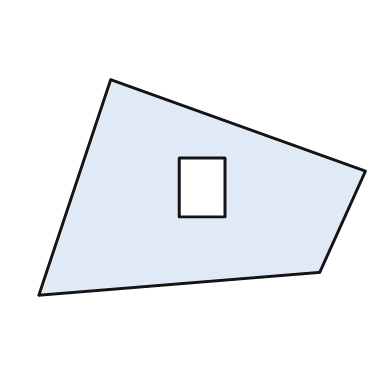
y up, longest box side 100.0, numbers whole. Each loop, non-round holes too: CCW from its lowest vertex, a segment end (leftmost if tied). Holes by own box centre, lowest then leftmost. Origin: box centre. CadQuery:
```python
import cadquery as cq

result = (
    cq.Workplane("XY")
    .moveTo(-50.0, -33.0)
    .lineTo(36.0, -26.0)
    .lineTo(50.0, 5.0)
    .lineTo(-28.0, 33.0)
    .close()
    .moveTo(-7.0, -9.0)
    .lineTo(7.0, -9.0)
    .lineTo(7.0, 9.0)
    .lineTo(-7.0, 9.0)
    .close()
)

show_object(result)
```